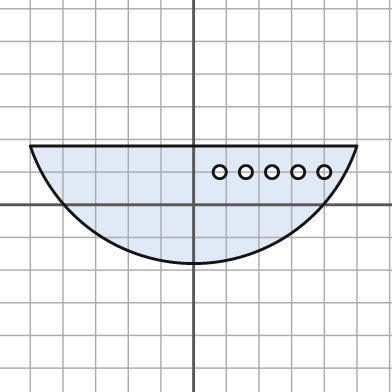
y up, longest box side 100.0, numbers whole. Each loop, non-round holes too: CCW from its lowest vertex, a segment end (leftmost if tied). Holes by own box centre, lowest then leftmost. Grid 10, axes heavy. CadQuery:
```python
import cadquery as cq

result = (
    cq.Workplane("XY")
    .moveTo(-50.0, 18.0)
    .threePointArc((0.0, -18.0), (50.0, 18.0))
    .close()
    .moveTo(8.0, 10.0)
    .circle(2.0)
    .moveTo(16.0, 10.0)
    .circle(2.0)
    .moveTo(24.0, 10.0)
    .circle(2.0)
    .moveTo(32.0, 10.0)
    .circle(2.0)
    .moveTo(40.0, 10.0)
    .circle(2.0)
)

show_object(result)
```